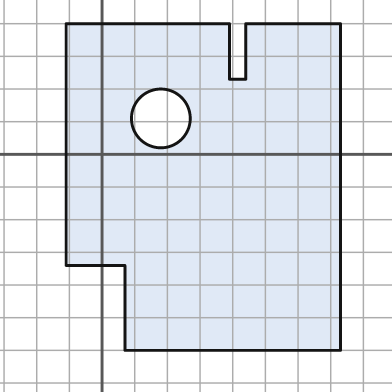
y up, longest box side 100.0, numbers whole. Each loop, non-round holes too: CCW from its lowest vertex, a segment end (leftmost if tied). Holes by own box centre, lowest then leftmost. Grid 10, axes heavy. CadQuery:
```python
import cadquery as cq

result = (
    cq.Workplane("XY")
    .moveTo(7.0, -60.0)
    .lineTo(73.0, -60.0)
    .lineTo(73.0, 40.0)
    .lineTo(44.0, 40.0)
    .lineTo(44.0, 23.0)
    .lineTo(39.0, 23.0)
    .lineTo(39.0, 40.0)
    .lineTo(-11.0, 40.0)
    .lineTo(-11.0, -34.0)
    .lineTo(7.0, -34.0)
    .close()
    .moveTo(18.0, 11.0)
    .circle(9.0)
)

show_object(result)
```